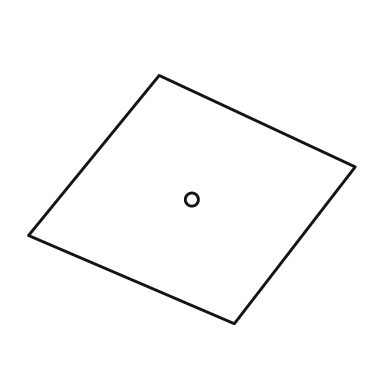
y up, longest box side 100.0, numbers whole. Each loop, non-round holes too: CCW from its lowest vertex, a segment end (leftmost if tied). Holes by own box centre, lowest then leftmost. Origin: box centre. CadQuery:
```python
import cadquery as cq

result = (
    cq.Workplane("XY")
    .moveTo(13.0, -38.0)
    .lineTo(50.0, 10.0)
    .lineTo(-10.0, 38.0)
    .lineTo(-50.0, -11.0)
    .close()
    .moveTo(0.0, 0.0)
    .circle(2.0)
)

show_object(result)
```